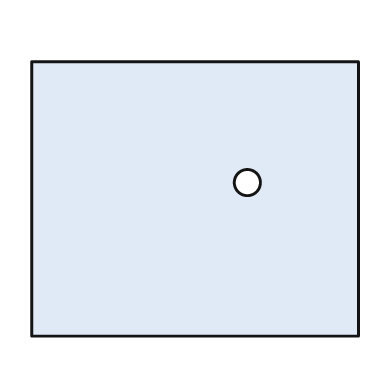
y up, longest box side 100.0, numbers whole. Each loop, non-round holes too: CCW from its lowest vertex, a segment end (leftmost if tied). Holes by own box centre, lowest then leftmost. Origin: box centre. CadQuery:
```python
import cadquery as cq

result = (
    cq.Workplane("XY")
    .moveTo(-50.0, -42.0)
    .lineTo(50.0, -42.0)
    .lineTo(50.0, 42.0)
    .lineTo(-50.0, 42.0)
    .close()
    .moveTo(16.0, 5.0)
    .circle(4.0)
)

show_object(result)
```